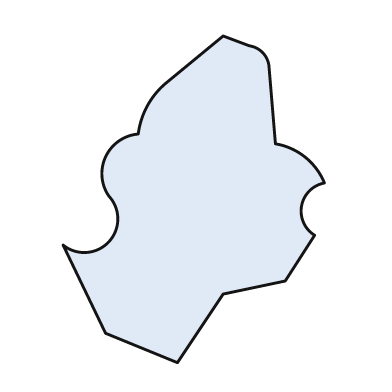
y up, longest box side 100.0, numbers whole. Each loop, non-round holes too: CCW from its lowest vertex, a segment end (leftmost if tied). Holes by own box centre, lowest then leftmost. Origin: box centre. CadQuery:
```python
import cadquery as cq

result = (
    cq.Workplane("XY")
    .moveTo(-5.0, -50.0)
    .lineTo(9.0, -29.0)
    .lineTo(28.0, -25.0)
    .lineTo(37.0, -11.0)
    .threePointArc((33.0, -2.0), (40.0, 5.0))
    .threePointArc((34.0, 13.0), (25.0, 17.0))
    .lineTo(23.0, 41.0)
    .threePointArc((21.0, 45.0), (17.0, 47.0))
    .lineTo(9.0, 50.0)
    .lineTo(-8.0, 36.0)
    .threePointArc((-14.0, 29.0), (-17.0, 20.0))
    .threePointArc((-27.0, 13.0), (-26.0, 1.0))
    .threePointArc((-26.0, -13.0), (-40.0, -14.0))
    .lineTo(-27.0, -41.0)
    .close()
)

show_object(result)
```